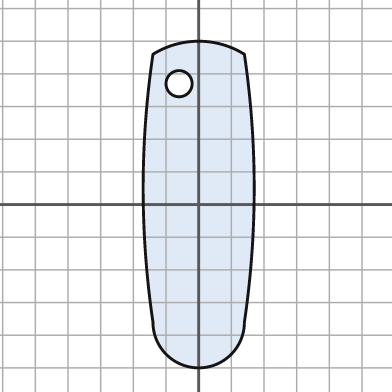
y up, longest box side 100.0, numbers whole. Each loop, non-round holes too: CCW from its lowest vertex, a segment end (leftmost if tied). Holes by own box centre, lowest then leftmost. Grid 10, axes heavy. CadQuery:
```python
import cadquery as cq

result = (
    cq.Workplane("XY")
    .moveTo(-14.0, -36.0)
    .threePointArc((0.0, -50.0), (14.0, -36.0))
    .threePointArc((17.0, 5.0), (14.0, 46.0))
    .threePointArc((0.0, 50.0), (-14.0, 46.0))
    .threePointArc((-17.0, 5.0), (-14.0, -36.0))
    .close()
    .moveTo(-6.0, 37.0)
    .circle(4.0)
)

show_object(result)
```